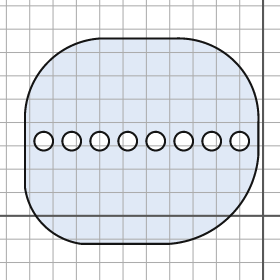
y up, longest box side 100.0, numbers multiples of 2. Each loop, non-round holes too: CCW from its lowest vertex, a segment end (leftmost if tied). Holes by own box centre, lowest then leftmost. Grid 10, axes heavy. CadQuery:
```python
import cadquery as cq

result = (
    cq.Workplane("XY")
    .moveTo(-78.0, -12.0)
    .lineTo(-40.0, -12.0)
    .threePointArc((-14.0, 0.0), (-2.0, 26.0))
    .lineTo(-2.0, 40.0)
    .threePointArc((-12.0, 66.0), (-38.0, 76.0))
    .lineTo(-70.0, 76.0)
    .threePointArc((-92.0, 66.0), (-102.0, 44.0))
    .lineTo(-102.0, 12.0)
    .threePointArc((-94.0, -4.0), (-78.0, -12.0))
    .close()
    .moveTo(-94.0, 32.0)
    .circle(4.0)
    .moveTo(-82.0, 32.0)
    .circle(4.0)
    .moveTo(-70.0, 32.0)
    .circle(4.0)
    .moveTo(-58.0, 32.0)
    .circle(4.0)
    .moveTo(-46.0, 32.0)
    .circle(4.0)
    .moveTo(-34.0, 32.0)
    .circle(4.0)
    .moveTo(-22.0, 32.0)
    .circle(4.0)
    .moveTo(-10.0, 32.0)
    .circle(4.0)
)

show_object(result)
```